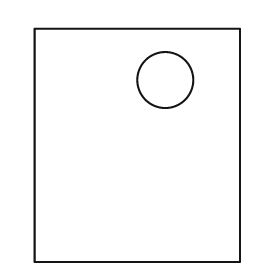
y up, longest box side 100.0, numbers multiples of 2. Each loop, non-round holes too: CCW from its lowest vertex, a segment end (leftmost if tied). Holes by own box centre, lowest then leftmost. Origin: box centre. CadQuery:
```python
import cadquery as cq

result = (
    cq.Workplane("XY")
    .moveTo(-44.0, -50.0)
    .lineTo(44.0, -50.0)
    .lineTo(44.0, 50.0)
    .lineTo(-44.0, 50.0)
    .close()
    .moveTo(12.0, 28.0)
    .circle(12.0)
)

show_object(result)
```